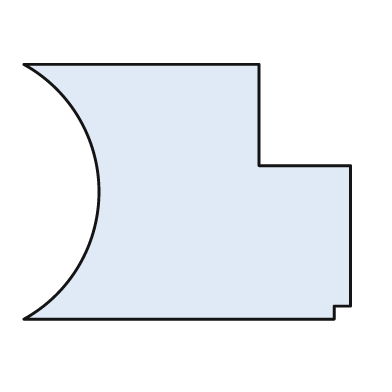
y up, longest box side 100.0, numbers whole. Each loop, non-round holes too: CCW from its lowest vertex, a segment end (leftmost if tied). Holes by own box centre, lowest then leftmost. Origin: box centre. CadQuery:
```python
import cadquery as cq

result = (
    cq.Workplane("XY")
    .moveTo(-50.0, -39.0)
    .lineTo(45.0, -39.0)
    .lineTo(45.0, -35.0)
    .lineTo(50.0, -35.0)
    .lineTo(50.0, 8.0)
    .lineTo(22.0, 8.0)
    .lineTo(22.0, 39.0)
    .lineTo(-50.0, 39.0)
    .threePointArc((-27.0, 0.0), (-50.0, -39.0))
    .close()
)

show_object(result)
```